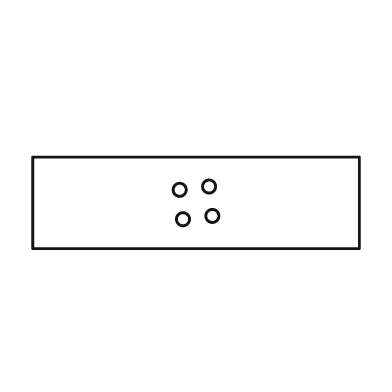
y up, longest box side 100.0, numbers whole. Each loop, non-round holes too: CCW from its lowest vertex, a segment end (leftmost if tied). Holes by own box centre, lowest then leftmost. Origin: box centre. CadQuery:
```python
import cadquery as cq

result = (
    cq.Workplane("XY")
    .moveTo(-50.0, -14.0)
    .lineTo(50.0, -14.0)
    .lineTo(50.0, 14.0)
    .lineTo(-50.0, 14.0)
    .close()
    .moveTo(-4.0, -5.0)
    .circle(2.0)
    .moveTo(5.0, -4.0)
    .circle(2.0)
    .moveTo(-5.0, 4.0)
    .circle(2.0)
    .moveTo(4.0, 5.0)
    .circle(2.0)
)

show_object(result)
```